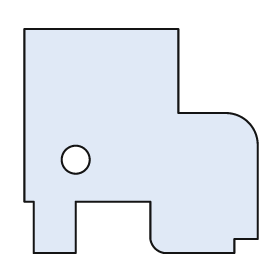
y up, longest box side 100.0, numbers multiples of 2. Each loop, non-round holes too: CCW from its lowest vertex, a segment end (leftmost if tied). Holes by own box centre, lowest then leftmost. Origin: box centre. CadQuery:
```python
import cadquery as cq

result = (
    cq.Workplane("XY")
    .moveTo(-46.0, -48.0)
    .lineTo(-28.0, -48.0)
    .lineTo(-28.0, -26.0)
    .lineTo(4.0, -26.0)
    .lineTo(4.0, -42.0)
    .threePointArc((6.0, -46.0), (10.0, -48.0))
    .lineTo(40.0, -48.0)
    .lineTo(40.0, -42.0)
    .lineTo(50.0, -42.0)
    .lineTo(50.0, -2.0)
    .threePointArc((46.0, 8.0), (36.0, 12.0))
    .lineTo(16.0, 12.0)
    .lineTo(16.0, 48.0)
    .lineTo(-50.0, 48.0)
    .lineTo(-50.0, -26.0)
    .lineTo(-46.0, -26.0)
    .close()
    .moveTo(-28.0, -8.0)
    .circle(6.0)
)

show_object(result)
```